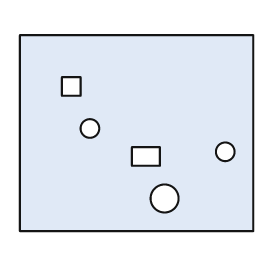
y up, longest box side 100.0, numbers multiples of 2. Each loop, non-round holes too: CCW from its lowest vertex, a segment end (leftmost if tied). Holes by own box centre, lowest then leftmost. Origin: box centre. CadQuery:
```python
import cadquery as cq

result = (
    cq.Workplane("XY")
    .moveTo(-50.0, -42.0)
    .lineTo(50.0, -42.0)
    .lineTo(50.0, 42.0)
    .lineTo(-50.0, 42.0)
    .close()
    .moveTo(12.0, -28.0)
    .circle(6.0)
    .moveTo(-2.0, -14.0)
    .lineTo(10.0, -14.0)
    .lineTo(10.0, -6.0)
    .lineTo(-2.0, -6.0)
    .close()
    .moveTo(38.0, -8.0)
    .circle(4.0)
    .moveTo(-20.0, 2.0)
    .circle(4.0)
    .moveTo(-32.0, 16.0)
    .lineTo(-24.0, 16.0)
    .lineTo(-24.0, 24.0)
    .lineTo(-32.0, 24.0)
    .close()
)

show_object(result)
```